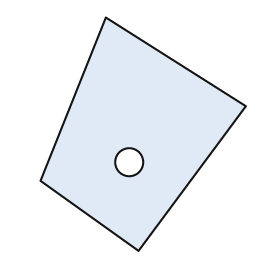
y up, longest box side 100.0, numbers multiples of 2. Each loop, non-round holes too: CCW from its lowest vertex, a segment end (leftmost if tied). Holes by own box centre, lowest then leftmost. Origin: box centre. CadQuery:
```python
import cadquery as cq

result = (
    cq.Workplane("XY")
    .moveTo(-2.0, -50.0)
    .lineTo(44.0, 12.0)
    .lineTo(-16.0, 50.0)
    .lineTo(-44.0, -20.0)
    .close()
    .moveTo(-6.0, -12.0)
    .circle(6.0)
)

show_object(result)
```